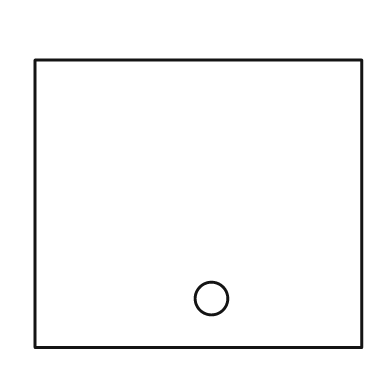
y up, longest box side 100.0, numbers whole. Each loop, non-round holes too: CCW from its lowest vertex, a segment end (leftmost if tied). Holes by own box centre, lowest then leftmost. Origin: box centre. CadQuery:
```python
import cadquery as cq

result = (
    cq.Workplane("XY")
    .moveTo(-50.0, -44.0)
    .lineTo(50.0, -44.0)
    .lineTo(50.0, 44.0)
    .lineTo(-50.0, 44.0)
    .close()
    .moveTo(4.0, -29.0)
    .circle(5.0)
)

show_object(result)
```